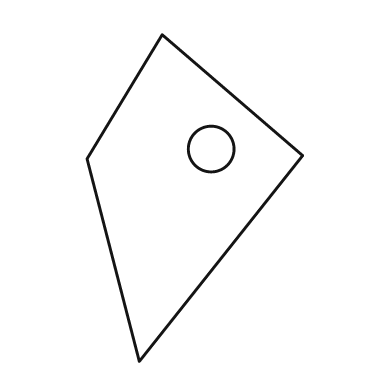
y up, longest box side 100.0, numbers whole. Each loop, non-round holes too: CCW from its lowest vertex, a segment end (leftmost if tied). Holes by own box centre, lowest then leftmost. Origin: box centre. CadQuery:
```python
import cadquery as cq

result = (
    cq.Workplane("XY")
    .moveTo(-17.0, -50.0)
    .lineTo(33.0, 13.0)
    .lineTo(-10.0, 50.0)
    .lineTo(-33.0, 12.0)
    .close()
    .moveTo(5.0, 15.0)
    .circle(7.0)
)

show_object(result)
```